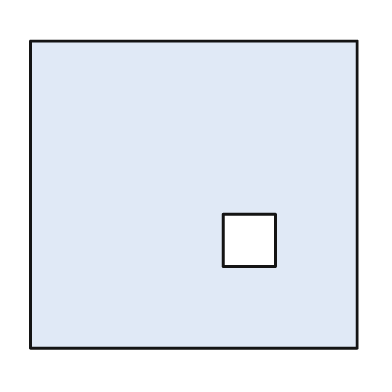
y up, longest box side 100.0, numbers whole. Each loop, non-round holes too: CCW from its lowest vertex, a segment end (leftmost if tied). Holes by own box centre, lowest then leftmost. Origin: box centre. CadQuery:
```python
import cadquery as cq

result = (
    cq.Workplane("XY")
    .moveTo(-50.0, -47.0)
    .lineTo(50.0, -47.0)
    .lineTo(50.0, 47.0)
    .lineTo(-50.0, 47.0)
    .close()
    .moveTo(9.0, -22.0)
    .lineTo(25.0, -22.0)
    .lineTo(25.0, -6.0)
    .lineTo(9.0, -6.0)
    .close()
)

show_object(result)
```